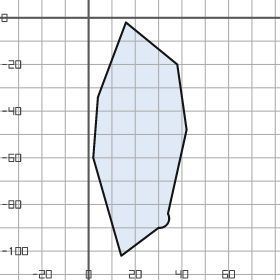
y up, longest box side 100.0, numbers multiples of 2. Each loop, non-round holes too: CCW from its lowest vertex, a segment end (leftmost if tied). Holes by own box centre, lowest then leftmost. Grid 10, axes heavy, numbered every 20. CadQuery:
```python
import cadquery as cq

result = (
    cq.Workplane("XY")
    .moveTo(14.0, -102.0)
    .lineTo(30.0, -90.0)
    .threePointArc((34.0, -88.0), (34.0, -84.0))
    .lineTo(42.0, -48.0)
    .lineTo(38.0, -20.0)
    .lineTo(16.0, -2.0)
    .lineTo(4.0, -34.0)
    .lineTo(2.0, -60.0)
    .close()
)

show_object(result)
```